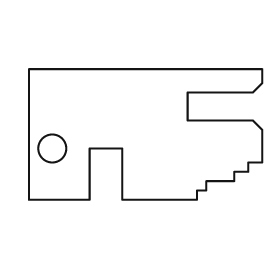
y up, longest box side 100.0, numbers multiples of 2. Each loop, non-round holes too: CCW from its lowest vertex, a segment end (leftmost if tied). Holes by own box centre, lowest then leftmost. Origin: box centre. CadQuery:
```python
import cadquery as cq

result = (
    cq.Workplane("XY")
    .moveTo(-50.0, -28.0)
    .lineTo(-24.0, -28.0)
    .lineTo(-24.0, -6.0)
    .lineTo(-10.0, -6.0)
    .lineTo(-10.0, -28.0)
    .lineTo(22.0, -28.0)
    .lineTo(22.0, -24.0)
    .lineTo(26.0, -24.0)
    .lineTo(26.0, -20.0)
    .lineTo(38.0, -20.0)
    .lineTo(38.0, -16.0)
    .lineTo(44.0, -16.0)
    .lineTo(44.0, -12.0)
    .lineTo(50.0, -12.0)
    .lineTo(50.0, 2.0)
    .lineTo(46.0, 6.0)
    .lineTo(18.0, 6.0)
    .lineTo(18.0, 18.0)
    .lineTo(46.0, 18.0)
    .lineTo(50.0, 22.0)
    .lineTo(50.0, 28.0)
    .lineTo(-50.0, 28.0)
    .close()
    .moveTo(-40.0, -6.0)
    .circle(6.0)
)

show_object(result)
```